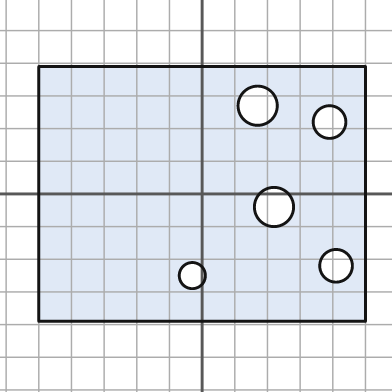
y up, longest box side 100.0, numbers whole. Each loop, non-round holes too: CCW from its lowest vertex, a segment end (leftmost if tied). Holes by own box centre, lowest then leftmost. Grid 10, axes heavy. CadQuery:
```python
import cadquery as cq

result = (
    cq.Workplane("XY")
    .moveTo(-50.0, -39.0)
    .lineTo(50.0, -39.0)
    .lineTo(50.0, 39.0)
    .lineTo(-50.0, 39.0)
    .close()
    .moveTo(-3.0, -25.0)
    .circle(4.0)
    .moveTo(41.0, -22.0)
    .circle(5.0)
    .moveTo(22.0, -4.0)
    .circle(6.0)
    .moveTo(39.0, 22.0)
    .circle(5.0)
    .moveTo(17.0, 27.0)
    .circle(6.0)
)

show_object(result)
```